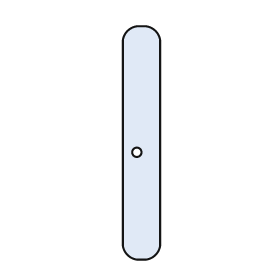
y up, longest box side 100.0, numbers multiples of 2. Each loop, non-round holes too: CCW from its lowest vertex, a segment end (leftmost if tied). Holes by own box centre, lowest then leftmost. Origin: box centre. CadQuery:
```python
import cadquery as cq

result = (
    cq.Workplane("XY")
    .moveTo(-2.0, -50.0)
    .lineTo(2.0, -50.0)
    .threePointArc((6.0, -48.0), (8.0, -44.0))
    .lineTo(8.0, 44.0)
    .threePointArc((6.0, 48.0), (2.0, 50.0))
    .lineTo(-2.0, 50.0)
    .threePointArc((-6.0, 48.0), (-8.0, 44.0))
    .lineTo(-8.0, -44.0)
    .threePointArc((-6.0, -48.0), (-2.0, -50.0))
    .close()
    .moveTo(-2.0, -4.0)
    .circle(2.0)
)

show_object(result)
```